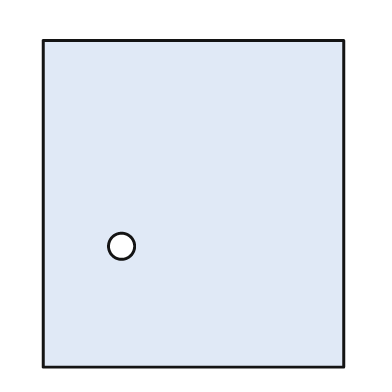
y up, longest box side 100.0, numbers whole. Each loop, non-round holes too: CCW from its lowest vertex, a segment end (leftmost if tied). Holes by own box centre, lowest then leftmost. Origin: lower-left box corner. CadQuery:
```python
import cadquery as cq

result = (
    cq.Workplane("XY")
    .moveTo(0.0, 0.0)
    .lineTo(92.0, 0.0)
    .lineTo(92.0, 100.0)
    .lineTo(0.0, 100.0)
    .close()
    .moveTo(24.0, 37.0)
    .circle(4.0)
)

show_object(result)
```